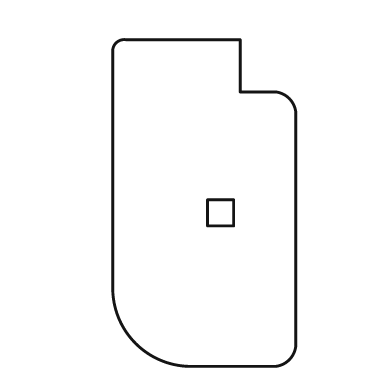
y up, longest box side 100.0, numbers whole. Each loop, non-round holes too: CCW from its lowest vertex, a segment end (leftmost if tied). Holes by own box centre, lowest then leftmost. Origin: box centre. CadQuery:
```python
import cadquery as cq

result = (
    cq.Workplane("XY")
    .moveTo(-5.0, -50.0)
    .lineTo(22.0, -50.0)
    .threePointArc((26.0, -48.0), (28.0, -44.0))
    .lineTo(28.0, 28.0)
    .threePointArc((26.0, 32.0), (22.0, 34.0))
    .lineTo(11.0, 34.0)
    .lineTo(11.0, 50.0)
    .lineTo(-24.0, 50.0)
    .threePointArc((-27.0, 49.0), (-28.0, 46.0))
    .lineTo(-28.0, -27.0)
    .threePointArc((-21.0, -43.0), (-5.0, -50.0))
    .close()
    .moveTo(1.0, -7.0)
    .lineTo(9.0, -7.0)
    .lineTo(9.0, 1.0)
    .lineTo(1.0, 1.0)
    .close()
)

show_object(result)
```